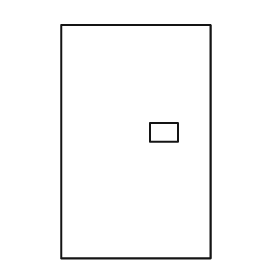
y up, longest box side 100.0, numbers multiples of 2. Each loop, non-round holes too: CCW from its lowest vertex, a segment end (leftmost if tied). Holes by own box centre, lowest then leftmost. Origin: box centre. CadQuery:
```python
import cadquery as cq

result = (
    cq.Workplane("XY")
    .moveTo(-32.0, -50.0)
    .lineTo(32.0, -50.0)
    .lineTo(32.0, 50.0)
    .lineTo(-32.0, 50.0)
    .close()
    .moveTo(6.0, 0.0)
    .lineTo(18.0, 0.0)
    .lineTo(18.0, 8.0)
    .lineTo(6.0, 8.0)
    .close()
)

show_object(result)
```